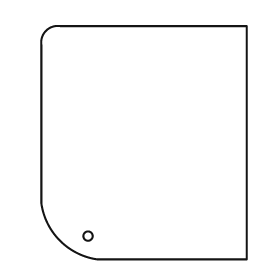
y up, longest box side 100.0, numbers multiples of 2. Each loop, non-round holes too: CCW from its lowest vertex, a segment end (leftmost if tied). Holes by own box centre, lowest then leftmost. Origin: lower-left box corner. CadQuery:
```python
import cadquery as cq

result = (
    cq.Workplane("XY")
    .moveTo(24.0, 0.0)
    .lineTo(88.0, 0.0)
    .lineTo(88.0, 100.0)
    .lineTo(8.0, 100.0)
    .threePointArc((2.0, 98.0), (0.0, 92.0))
    .lineTo(0.0, 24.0)
    .threePointArc((8.0, 8.0), (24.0, 0.0))
    .close()
    .moveTo(20.0, 10.0)
    .circle(2.0)
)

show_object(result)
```